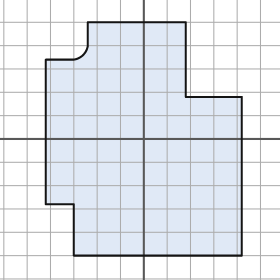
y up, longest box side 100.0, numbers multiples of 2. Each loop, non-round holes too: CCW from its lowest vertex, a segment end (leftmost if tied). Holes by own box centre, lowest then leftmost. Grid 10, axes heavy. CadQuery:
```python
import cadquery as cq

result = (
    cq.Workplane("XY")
    .moveTo(-30.0, -50.0)
    .lineTo(42.0, -50.0)
    .lineTo(42.0, 18.0)
    .lineTo(18.0, 18.0)
    .lineTo(18.0, 50.0)
    .lineTo(-24.0, 50.0)
    .lineTo(-24.0, 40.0)
    .threePointArc((-26.0, 36.0), (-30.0, 34.0))
    .lineTo(-42.0, 34.0)
    .lineTo(-42.0, -28.0)
    .lineTo(-30.0, -28.0)
    .close()
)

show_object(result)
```